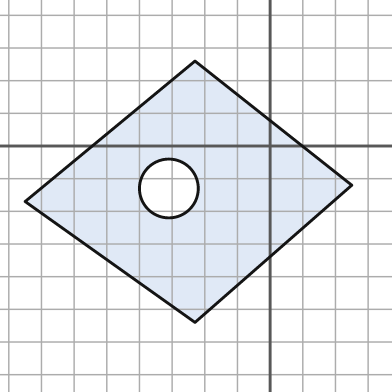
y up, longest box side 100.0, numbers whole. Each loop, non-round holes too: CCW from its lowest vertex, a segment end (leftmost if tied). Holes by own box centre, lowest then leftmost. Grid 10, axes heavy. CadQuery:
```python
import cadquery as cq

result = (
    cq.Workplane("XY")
    .moveTo(-23.0, -54.0)
    .lineTo(25.0, -12.0)
    .lineTo(-23.0, 26.0)
    .lineTo(-75.0, -17.0)
    .close()
    .moveTo(-31.0, -13.0)
    .circle(9.0)
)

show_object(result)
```